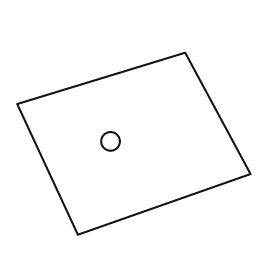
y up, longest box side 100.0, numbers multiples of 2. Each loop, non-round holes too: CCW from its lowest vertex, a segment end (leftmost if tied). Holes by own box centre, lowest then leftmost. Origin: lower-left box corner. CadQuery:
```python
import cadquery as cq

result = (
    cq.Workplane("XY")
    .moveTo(26.0, 0.0)
    .lineTo(100.0, 26.0)
    .lineTo(72.0, 78.0)
    .lineTo(0.0, 56.0)
    .close()
    .moveTo(40.0, 40.0)
    .circle(4.0)
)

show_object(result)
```